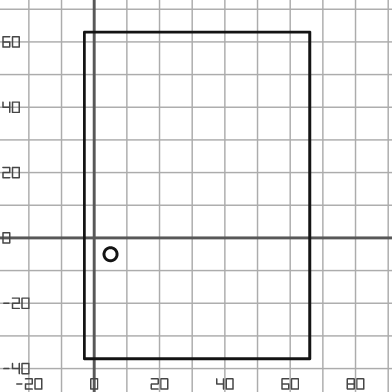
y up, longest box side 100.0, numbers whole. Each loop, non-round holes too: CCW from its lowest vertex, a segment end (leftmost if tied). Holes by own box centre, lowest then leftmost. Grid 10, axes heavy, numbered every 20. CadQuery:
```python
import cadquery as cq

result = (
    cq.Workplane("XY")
    .moveTo(-3.0, -37.0)
    .lineTo(66.0, -37.0)
    .lineTo(66.0, 63.0)
    .lineTo(-3.0, 63.0)
    .close()
    .moveTo(5.0, -5.0)
    .circle(2.0)
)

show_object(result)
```